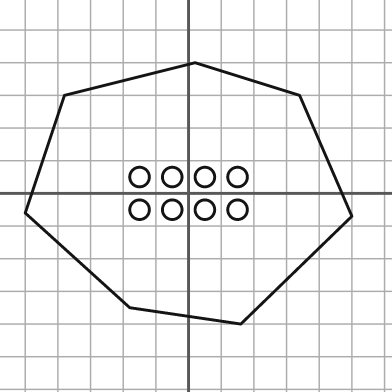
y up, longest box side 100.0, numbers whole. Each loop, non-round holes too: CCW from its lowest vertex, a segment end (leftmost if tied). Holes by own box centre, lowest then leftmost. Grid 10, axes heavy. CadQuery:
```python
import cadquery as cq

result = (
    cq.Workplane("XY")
    .moveTo(16.0, -40.0)
    .lineTo(50.0, -7.0)
    .lineTo(34.0, 30.0)
    .lineTo(2.0, 40.0)
    .lineTo(-38.0, 30.0)
    .lineTo(-50.0, -6.0)
    .lineTo(-18.0, -35.0)
    .close()
    .moveTo(-15.0, -5.0)
    .circle(3.0)
    .moveTo(-5.0, -5.0)
    .circle(3.0)
    .moveTo(5.0, -5.0)
    .circle(3.0)
    .moveTo(15.0, -5.0)
    .circle(3.0)
    .moveTo(-15.0, 5.0)
    .circle(3.0)
    .moveTo(-5.0, 5.0)
    .circle(3.0)
    .moveTo(5.0, 5.0)
    .circle(3.0)
    .moveTo(15.0, 5.0)
    .circle(3.0)
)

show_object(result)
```